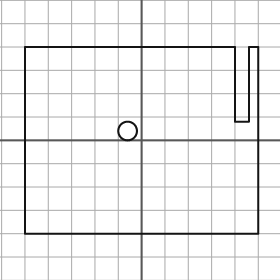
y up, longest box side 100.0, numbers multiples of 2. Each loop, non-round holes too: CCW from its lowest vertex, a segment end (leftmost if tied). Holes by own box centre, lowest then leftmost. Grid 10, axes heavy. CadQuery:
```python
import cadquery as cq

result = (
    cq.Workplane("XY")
    .moveTo(-50.0, -40.0)
    .lineTo(50.0, -40.0)
    .lineTo(50.0, 40.0)
    .lineTo(46.0, 40.0)
    .lineTo(46.0, 8.0)
    .lineTo(40.0, 8.0)
    .lineTo(40.0, 40.0)
    .lineTo(-50.0, 40.0)
    .close()
    .moveTo(-6.0, 4.0)
    .circle(4.0)
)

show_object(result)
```